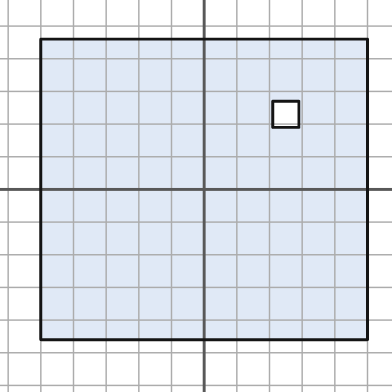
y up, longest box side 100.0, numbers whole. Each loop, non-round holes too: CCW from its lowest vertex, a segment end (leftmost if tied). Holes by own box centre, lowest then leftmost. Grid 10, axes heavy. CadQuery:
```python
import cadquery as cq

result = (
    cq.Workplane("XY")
    .moveTo(-50.0, -46.0)
    .lineTo(50.0, -46.0)
    .lineTo(50.0, 46.0)
    .lineTo(-50.0, 46.0)
    .close()
    .moveTo(21.0, 19.0)
    .lineTo(29.0, 19.0)
    .lineTo(29.0, 27.0)
    .lineTo(21.0, 27.0)
    .close()
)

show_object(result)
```